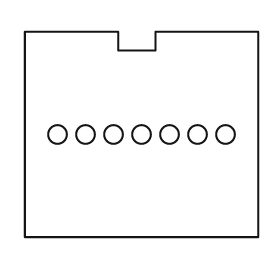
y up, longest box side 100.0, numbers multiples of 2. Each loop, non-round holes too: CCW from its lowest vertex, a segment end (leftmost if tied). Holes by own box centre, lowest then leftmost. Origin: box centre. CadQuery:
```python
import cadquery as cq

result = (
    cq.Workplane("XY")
    .moveTo(-50.0, -44.0)
    .lineTo(50.0, -44.0)
    .lineTo(50.0, 44.0)
    .lineTo(6.0, 44.0)
    .lineTo(6.0, 36.0)
    .lineTo(-10.0, 36.0)
    .lineTo(-10.0, 44.0)
    .lineTo(-50.0, 44.0)
    .close()
    .moveTo(-36.0, 0.0)
    .circle(4.0)
    .moveTo(-24.0, 0.0)
    .circle(4.0)
    .moveTo(-12.0, 0.0)
    .circle(4.0)
    .moveTo(0.0, 0.0)
    .circle(4.0)
    .moveTo(12.0, 0.0)
    .circle(4.0)
    .moveTo(24.0, 0.0)
    .circle(4.0)
    .moveTo(36.0, 0.0)
    .circle(4.0)
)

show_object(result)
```